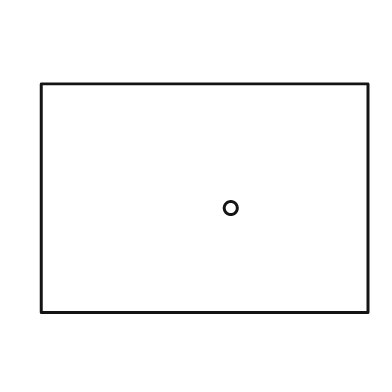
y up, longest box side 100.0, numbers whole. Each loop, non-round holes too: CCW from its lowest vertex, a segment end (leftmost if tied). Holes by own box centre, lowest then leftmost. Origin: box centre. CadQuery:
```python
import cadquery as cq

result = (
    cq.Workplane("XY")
    .moveTo(-50.0, -35.0)
    .lineTo(50.0, -35.0)
    .lineTo(50.0, 35.0)
    .lineTo(-50.0, 35.0)
    .close()
    .moveTo(8.0, -3.0)
    .circle(2.0)
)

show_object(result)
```